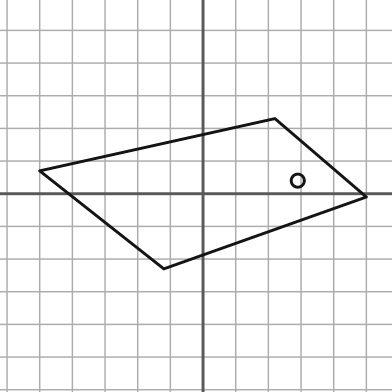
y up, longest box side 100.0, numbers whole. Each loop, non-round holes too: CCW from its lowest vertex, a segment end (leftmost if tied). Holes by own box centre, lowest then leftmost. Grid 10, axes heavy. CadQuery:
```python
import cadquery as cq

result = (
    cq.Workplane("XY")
    .moveTo(-12.0, -23.0)
    .lineTo(50.0, -1.0)
    .lineTo(22.0, 23.0)
    .lineTo(-50.0, 7.0)
    .close()
    .moveTo(29.0, 4.0)
    .circle(2.0)
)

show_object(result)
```